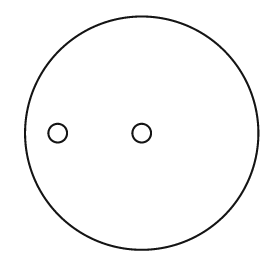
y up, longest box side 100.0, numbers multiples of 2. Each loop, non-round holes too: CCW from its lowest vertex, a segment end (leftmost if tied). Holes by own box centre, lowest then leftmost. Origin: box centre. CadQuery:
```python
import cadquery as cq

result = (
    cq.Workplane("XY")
    .moveTo(0.0, 0.0)
    .circle(50.0)
    .moveTo(-36.0, 0.0)
    .circle(4.0)
    .moveTo(0.0, 0.0)
    .circle(4.0)
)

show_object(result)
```